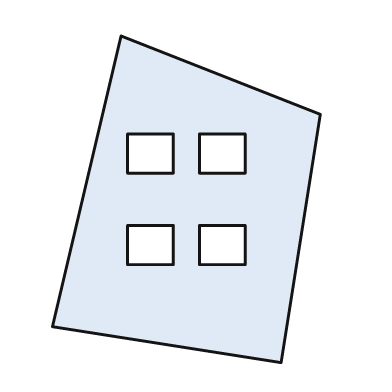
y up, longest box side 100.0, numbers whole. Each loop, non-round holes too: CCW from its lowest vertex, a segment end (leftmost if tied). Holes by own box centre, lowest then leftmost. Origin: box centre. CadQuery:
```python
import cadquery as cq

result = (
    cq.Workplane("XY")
    .moveTo(29.0, -50.0)
    .lineTo(41.0, 26.0)
    .lineTo(-20.0, 50.0)
    .lineTo(-41.0, -39.0)
    .close()
    .moveTo(-18.0, -20.0)
    .lineTo(-4.0, -20.0)
    .lineTo(-4.0, -8.0)
    .lineTo(-18.0, -8.0)
    .close()
    .moveTo(4.0, -20.0)
    .lineTo(18.0, -20.0)
    .lineTo(18.0, -8.0)
    .lineTo(4.0, -8.0)
    .close()
    .moveTo(-18.0, 8.0)
    .lineTo(-4.0, 8.0)
    .lineTo(-4.0, 20.0)
    .lineTo(-18.0, 20.0)
    .close()
    .moveTo(4.0, 8.0)
    .lineTo(18.0, 8.0)
    .lineTo(18.0, 20.0)
    .lineTo(4.0, 20.0)
    .close()
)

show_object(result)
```